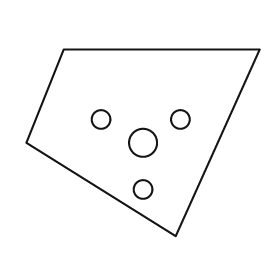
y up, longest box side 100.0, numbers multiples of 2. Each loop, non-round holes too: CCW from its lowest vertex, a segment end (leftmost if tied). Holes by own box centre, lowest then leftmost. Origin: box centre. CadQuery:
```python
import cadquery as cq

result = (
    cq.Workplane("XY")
    .moveTo(14.0, -40.0)
    .lineTo(50.0, 40.0)
    .lineTo(-34.0, 40.0)
    .lineTo(-50.0, 0.0)
    .close()
    .moveTo(0.0, -20.0)
    .circle(4.0)
    .moveTo(0.0, 0.0)
    .circle(6.0)
    .moveTo(-18.0, 10.0)
    .circle(4.0)
    .moveTo(16.0, 10.0)
    .circle(4.0)
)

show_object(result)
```